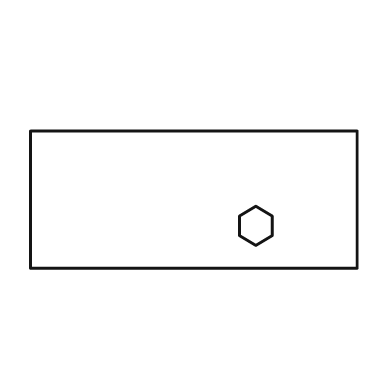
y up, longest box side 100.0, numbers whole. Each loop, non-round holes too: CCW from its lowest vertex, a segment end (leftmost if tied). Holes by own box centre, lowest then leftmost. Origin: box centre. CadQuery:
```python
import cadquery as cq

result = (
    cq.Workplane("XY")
    .moveTo(-50.0, -21.0)
    .lineTo(50.0, -21.0)
    .lineTo(50.0, 21.0)
    .lineTo(-50.0, 21.0)
    .close()
    .moveTo(19.0, -14.0)
    .lineTo(24.0, -11.0)
    .lineTo(24.0, -5.0)
    .lineTo(19.0, -2.0)
    .lineTo(14.0, -5.0)
    .lineTo(14.0, -11.0)
    .close()
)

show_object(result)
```